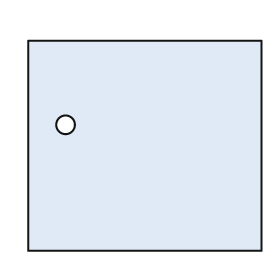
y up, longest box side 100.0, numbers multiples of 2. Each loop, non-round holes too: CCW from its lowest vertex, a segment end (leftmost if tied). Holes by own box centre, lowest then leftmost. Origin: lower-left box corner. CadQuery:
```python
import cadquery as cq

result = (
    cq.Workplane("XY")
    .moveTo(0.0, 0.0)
    .lineTo(100.0, 0.0)
    .lineTo(100.0, 90.0)
    .lineTo(0.0, 90.0)
    .close()
    .moveTo(16.0, 54.0)
    .circle(4.0)
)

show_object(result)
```